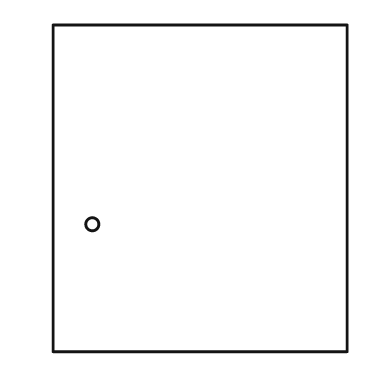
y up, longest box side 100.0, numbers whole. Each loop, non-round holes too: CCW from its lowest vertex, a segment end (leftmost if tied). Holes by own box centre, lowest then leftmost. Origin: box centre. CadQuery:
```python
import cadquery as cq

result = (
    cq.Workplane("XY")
    .moveTo(-45.0, -50.0)
    .lineTo(45.0, -50.0)
    .lineTo(45.0, 50.0)
    .lineTo(-45.0, 50.0)
    .close()
    .moveTo(-33.0, -11.0)
    .circle(2.0)
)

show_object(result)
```